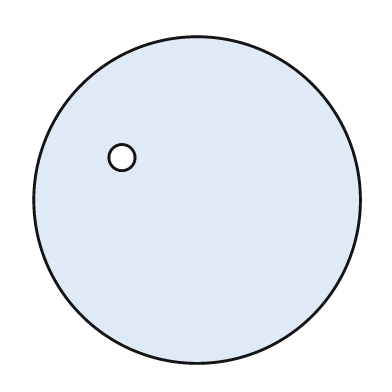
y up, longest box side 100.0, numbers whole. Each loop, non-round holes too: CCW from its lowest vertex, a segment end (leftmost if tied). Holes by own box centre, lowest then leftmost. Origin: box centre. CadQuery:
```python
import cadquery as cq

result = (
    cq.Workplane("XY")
    .moveTo(0.0, 0.0)
    .circle(50.0)
    .moveTo(-23.0, 13.0)
    .circle(4.0)
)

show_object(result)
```